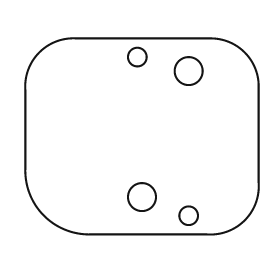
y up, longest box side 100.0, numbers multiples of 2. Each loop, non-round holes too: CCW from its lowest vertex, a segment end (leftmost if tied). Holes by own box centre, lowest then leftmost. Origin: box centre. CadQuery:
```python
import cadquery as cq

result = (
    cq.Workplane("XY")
    .moveTo(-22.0, -42.0)
    .lineTo(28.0, -42.0)
    .threePointArc((44.0, -36.0), (50.0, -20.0))
    .lineTo(50.0, 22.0)
    .threePointArc((44.0, 36.0), (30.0, 42.0))
    .lineTo(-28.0, 42.0)
    .threePointArc((-44.0, 36.0), (-50.0, 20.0))
    .lineTo(-50.0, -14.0)
    .threePointArc((-42.0, -34.0), (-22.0, -42.0))
    .close()
    .moveTo(20.0, -34.0)
    .circle(4.0)
    .moveTo(0.0, -26.0)
    .circle(6.0)
    .moveTo(20.0, 28.0)
    .circle(6.0)
    .moveTo(-2.0, 34.0)
    .circle(4.0)
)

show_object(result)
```